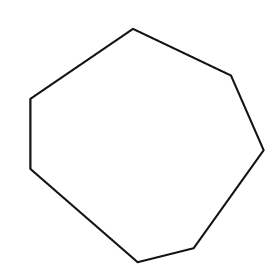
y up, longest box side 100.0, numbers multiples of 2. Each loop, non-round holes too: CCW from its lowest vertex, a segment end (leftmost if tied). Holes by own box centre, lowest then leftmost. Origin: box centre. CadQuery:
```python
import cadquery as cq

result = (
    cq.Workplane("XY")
    .moveTo(-4.0, -50.0)
    .lineTo(20.0, -44.0)
    .lineTo(50.0, -2.0)
    .lineTo(36.0, 30.0)
    .lineTo(-6.0, 50.0)
    .lineTo(-50.0, 20.0)
    .lineTo(-50.0, -10.0)
    .close()
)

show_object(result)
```